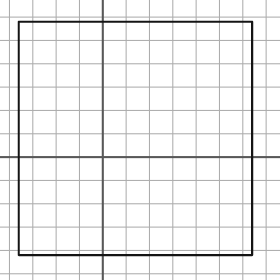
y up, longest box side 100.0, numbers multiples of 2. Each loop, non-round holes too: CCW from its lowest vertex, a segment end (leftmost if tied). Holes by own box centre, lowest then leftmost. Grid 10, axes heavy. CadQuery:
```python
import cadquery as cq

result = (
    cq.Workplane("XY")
    .moveTo(-36.0, -42.0)
    .lineTo(64.0, -42.0)
    .lineTo(64.0, 58.0)
    .lineTo(-36.0, 58.0)
    .close()
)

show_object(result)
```